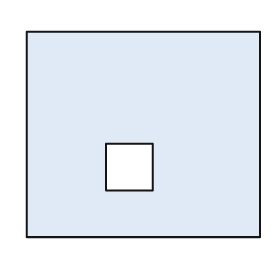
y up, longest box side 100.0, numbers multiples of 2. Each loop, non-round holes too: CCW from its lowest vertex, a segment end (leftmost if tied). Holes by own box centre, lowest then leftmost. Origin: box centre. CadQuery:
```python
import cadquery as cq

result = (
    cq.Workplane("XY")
    .moveTo(-50.0, -44.0)
    .lineTo(50.0, -44.0)
    .lineTo(50.0, 44.0)
    .lineTo(-50.0, 44.0)
    .close()
    .moveTo(-16.0, -24.0)
    .lineTo(4.0, -24.0)
    .lineTo(4.0, -4.0)
    .lineTo(-16.0, -4.0)
    .close()
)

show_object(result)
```